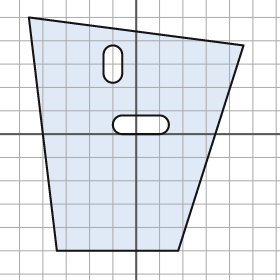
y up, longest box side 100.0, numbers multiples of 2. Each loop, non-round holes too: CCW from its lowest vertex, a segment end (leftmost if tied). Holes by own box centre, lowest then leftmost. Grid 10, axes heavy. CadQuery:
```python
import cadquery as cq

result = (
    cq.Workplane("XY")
    .moveTo(-34.0, -50.0)
    .lineTo(18.0, -50.0)
    .lineTo(46.0, 38.0)
    .lineTo(-46.0, 50.0)
    .close()
    .moveTo(-6.0, 0.0)
    .lineTo(10.0, 0.0)
    .threePointArc((14.0, 4.0), (10.0, 8.0))
    .lineTo(-6.0, 8.0)
    .threePointArc((-10.0, 4.0), (-6.0, 0.0))
    .close()
    .moveTo(-14.0, 26.0)
    .threePointArc((-10.0, 22.0), (-6.0, 26.0))
    .lineTo(-6.0, 34.0)
    .threePointArc((-10.0, 38.0), (-14.0, 34.0))
    .close()
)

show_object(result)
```